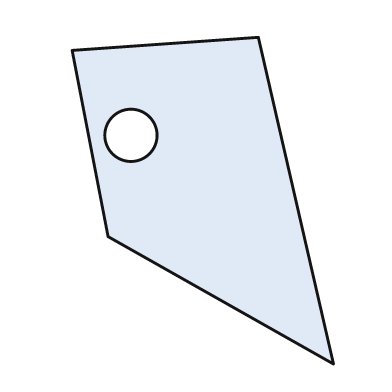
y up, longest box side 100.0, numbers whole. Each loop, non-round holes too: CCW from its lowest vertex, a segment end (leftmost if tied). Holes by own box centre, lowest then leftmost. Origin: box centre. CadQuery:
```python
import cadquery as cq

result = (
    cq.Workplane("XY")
    .moveTo(40.0, -50.0)
    .lineTo(17.0, 50.0)
    .lineTo(-40.0, 46.0)
    .lineTo(-29.0, -11.0)
    .close()
    .moveTo(-22.0, 20.0)
    .circle(8.0)
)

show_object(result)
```